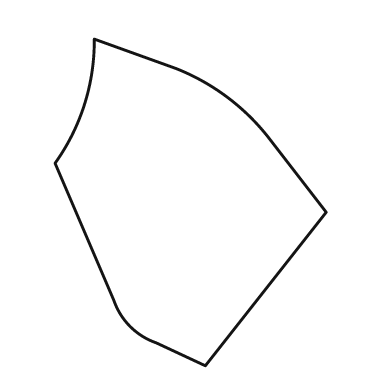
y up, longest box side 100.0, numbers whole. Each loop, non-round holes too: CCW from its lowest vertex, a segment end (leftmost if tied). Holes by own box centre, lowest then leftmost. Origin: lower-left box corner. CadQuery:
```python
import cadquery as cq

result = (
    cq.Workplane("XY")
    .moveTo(46.0, 0.0)
    .lineTo(83.0, 47.0)
    .lineTo(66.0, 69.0)
    .threePointArc((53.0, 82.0), (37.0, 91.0))
    .lineTo(12.0, 100.0)
    .threePointArc((9.0, 80.0), (0.0, 62.0))
    .lineTo(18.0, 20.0)
    .threePointArc((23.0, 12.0), (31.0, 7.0))
    .close()
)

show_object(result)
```